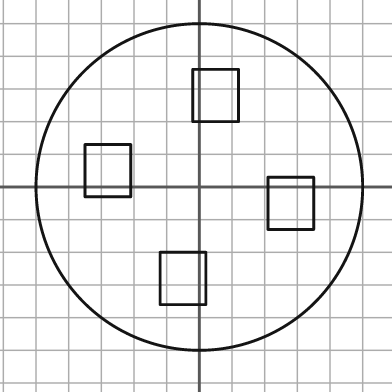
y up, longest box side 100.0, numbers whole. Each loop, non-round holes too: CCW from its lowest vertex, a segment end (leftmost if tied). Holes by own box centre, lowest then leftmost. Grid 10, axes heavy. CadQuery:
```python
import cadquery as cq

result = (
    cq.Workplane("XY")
    .moveTo(0.0, 0.0)
    .circle(50.0)
    .moveTo(-12.0, -36.0)
    .lineTo(2.0, -36.0)
    .lineTo(2.0, -20.0)
    .lineTo(-12.0, -20.0)
    .close()
    .moveTo(21.0, -13.0)
    .lineTo(35.0, -13.0)
    .lineTo(35.0, 3.0)
    .lineTo(21.0, 3.0)
    .close()
    .moveTo(-35.0, -3.0)
    .lineTo(-21.0, -3.0)
    .lineTo(-21.0, 13.0)
    .lineTo(-35.0, 13.0)
    .close()
    .moveTo(-2.0, 20.0)
    .lineTo(12.0, 20.0)
    .lineTo(12.0, 36.0)
    .lineTo(-2.0, 36.0)
    .close()
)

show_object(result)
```